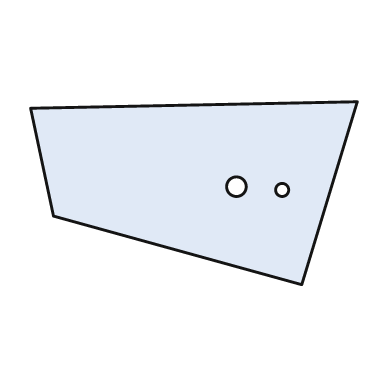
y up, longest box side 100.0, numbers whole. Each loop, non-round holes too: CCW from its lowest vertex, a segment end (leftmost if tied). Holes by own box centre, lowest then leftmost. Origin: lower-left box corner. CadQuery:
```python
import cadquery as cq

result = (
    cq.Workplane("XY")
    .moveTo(83.0, 0.0)
    .lineTo(100.0, 56.0)
    .lineTo(0.0, 54.0)
    .lineTo(7.0, 21.0)
    .close()
    .moveTo(77.0, 29.0)
    .circle(2.0)
    .moveTo(63.0, 30.0)
    .circle(3.0)
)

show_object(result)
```